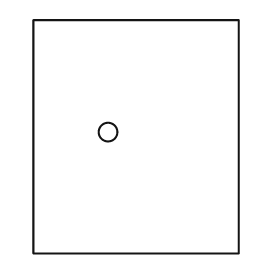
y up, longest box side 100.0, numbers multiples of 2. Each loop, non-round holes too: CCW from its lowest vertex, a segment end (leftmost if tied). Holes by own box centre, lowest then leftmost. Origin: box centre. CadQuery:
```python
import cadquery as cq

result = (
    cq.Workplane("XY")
    .moveTo(-44.0, -50.0)
    .lineTo(44.0, -50.0)
    .lineTo(44.0, 50.0)
    .lineTo(-44.0, 50.0)
    .close()
    .moveTo(-12.0, 2.0)
    .circle(4.0)
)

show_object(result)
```